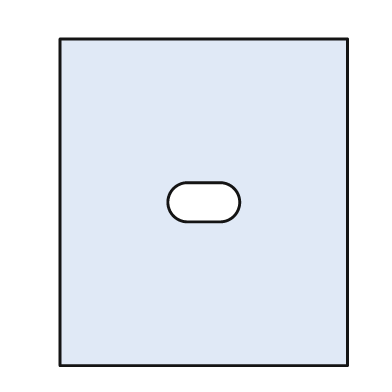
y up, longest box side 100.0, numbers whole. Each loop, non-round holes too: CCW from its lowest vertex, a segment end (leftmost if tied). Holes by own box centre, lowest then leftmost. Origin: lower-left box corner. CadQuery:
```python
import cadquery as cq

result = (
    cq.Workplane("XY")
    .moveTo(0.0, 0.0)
    .lineTo(88.0, 0.0)
    .lineTo(88.0, 100.0)
    .lineTo(0.0, 100.0)
    .close()
    .moveTo(39.0, 44.0)
    .lineTo(49.0, 44.0)
    .threePointArc((55.0, 50.0), (49.0, 56.0))
    .lineTo(39.0, 56.0)
    .threePointArc((33.0, 50.0), (39.0, 44.0))
    .close()
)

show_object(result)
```